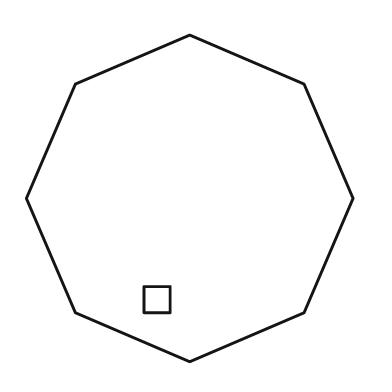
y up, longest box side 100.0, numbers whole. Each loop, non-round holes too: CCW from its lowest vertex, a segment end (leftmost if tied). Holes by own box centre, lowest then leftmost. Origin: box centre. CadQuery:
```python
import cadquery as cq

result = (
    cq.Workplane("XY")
    .moveTo(0.0, -50.0)
    .lineTo(35.0, -35.0)
    .lineTo(50.0, 0.0)
    .lineTo(35.0, 35.0)
    .lineTo(0.0, 50.0)
    .lineTo(-35.0, 35.0)
    .lineTo(-50.0, 0.0)
    .lineTo(-35.0, -35.0)
    .close()
    .moveTo(-14.0, -35.0)
    .lineTo(-6.0, -35.0)
    .lineTo(-6.0, -27.0)
    .lineTo(-14.0, -27.0)
    .close()
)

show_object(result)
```